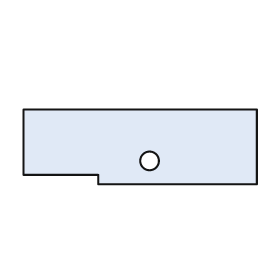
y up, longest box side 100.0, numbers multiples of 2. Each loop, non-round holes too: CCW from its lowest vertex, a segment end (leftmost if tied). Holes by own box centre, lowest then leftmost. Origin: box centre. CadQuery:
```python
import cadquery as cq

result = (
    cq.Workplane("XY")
    .moveTo(-18.0, -16.0)
    .lineTo(50.0, -16.0)
    .lineTo(50.0, 16.0)
    .lineTo(-50.0, 16.0)
    .lineTo(-50.0, -12.0)
    .lineTo(-18.0, -12.0)
    .close()
    .moveTo(4.0, -6.0)
    .circle(4.0)
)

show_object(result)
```